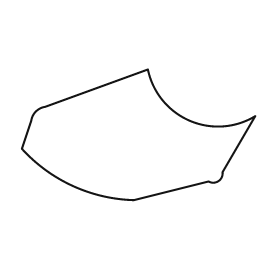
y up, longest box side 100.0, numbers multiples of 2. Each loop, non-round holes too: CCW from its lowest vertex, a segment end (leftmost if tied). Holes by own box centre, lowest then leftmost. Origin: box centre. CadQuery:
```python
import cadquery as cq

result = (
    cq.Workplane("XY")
    .moveTo(-2.0, -28.0)
    .lineTo(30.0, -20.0)
    .threePointArc((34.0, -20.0), (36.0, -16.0))
    .lineTo(50.0, 8.0)
    .threePointArc((22.0, 6.0), (4.0, 28.0))
    .lineTo(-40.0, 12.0)
    .threePointArc((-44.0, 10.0), (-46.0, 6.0))
    .lineTo(-50.0, -6.0)
    .threePointArc((-28.0, -22.0), (-2.0, -28.0))
    .close()
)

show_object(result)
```